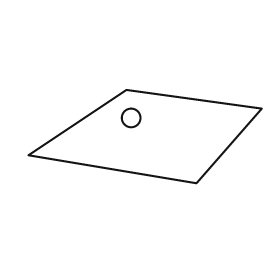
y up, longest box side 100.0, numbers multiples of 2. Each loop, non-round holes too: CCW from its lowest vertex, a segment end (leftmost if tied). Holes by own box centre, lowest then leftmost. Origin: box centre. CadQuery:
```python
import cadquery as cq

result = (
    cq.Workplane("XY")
    .moveTo(22.0, -20.0)
    .lineTo(50.0, 12.0)
    .lineTo(-8.0, 20.0)
    .lineTo(-50.0, -8.0)
    .close()
    .moveTo(-6.0, 8.0)
    .circle(4.0)
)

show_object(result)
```